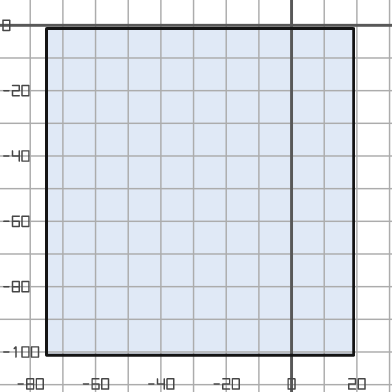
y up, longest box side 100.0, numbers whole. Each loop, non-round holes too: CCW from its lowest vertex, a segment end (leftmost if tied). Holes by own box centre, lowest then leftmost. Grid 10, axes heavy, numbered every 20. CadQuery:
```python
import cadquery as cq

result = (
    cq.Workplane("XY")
    .moveTo(-75.0, -101.0)
    .lineTo(19.0, -101.0)
    .lineTo(19.0, -1.0)
    .lineTo(-75.0, -1.0)
    .close()
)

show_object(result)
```